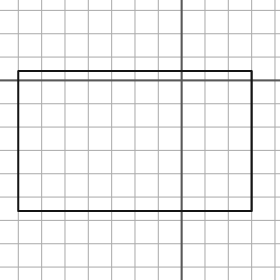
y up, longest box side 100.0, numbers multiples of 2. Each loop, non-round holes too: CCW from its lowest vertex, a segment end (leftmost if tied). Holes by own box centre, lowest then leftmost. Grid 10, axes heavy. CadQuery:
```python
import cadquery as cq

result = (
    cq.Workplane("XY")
    .moveTo(-70.0, -56.0)
    .lineTo(30.0, -56.0)
    .lineTo(30.0, 4.0)
    .lineTo(-70.0, 4.0)
    .close()
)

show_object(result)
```